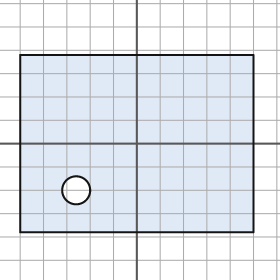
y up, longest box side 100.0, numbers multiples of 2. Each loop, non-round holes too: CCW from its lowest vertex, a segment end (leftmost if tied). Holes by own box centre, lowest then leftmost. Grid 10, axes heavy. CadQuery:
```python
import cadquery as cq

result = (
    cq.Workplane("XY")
    .moveTo(-50.0, -38.0)
    .lineTo(50.0, -38.0)
    .lineTo(50.0, 38.0)
    .lineTo(-50.0, 38.0)
    .close()
    .moveTo(-26.0, -20.0)
    .circle(6.0)
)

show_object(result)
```